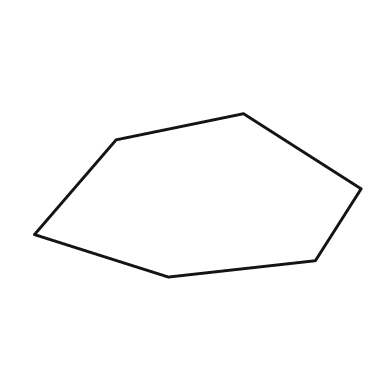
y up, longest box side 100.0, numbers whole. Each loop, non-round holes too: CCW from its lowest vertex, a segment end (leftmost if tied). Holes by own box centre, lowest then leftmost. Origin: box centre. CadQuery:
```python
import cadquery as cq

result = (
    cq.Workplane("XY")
    .moveTo(-9.0, -25.0)
    .lineTo(36.0, -20.0)
    .lineTo(50.0, 2.0)
    .lineTo(14.0, 25.0)
    .lineTo(-25.0, 17.0)
    .lineTo(-50.0, -12.0)
    .close()
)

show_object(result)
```